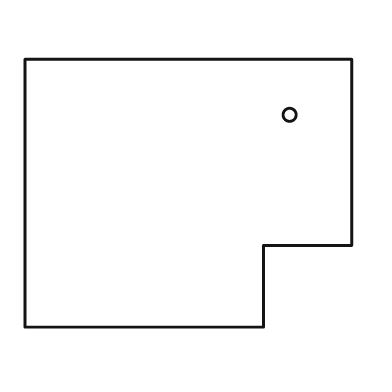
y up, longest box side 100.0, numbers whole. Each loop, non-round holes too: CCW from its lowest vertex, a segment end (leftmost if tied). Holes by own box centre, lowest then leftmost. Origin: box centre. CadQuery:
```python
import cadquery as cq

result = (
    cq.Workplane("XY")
    .moveTo(-50.0, -41.0)
    .lineTo(23.0, -41.0)
    .lineTo(23.0, -16.0)
    .lineTo(50.0, -16.0)
    .lineTo(50.0, 41.0)
    .lineTo(-50.0, 41.0)
    .close()
    .moveTo(31.0, 24.0)
    .circle(2.0)
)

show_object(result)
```